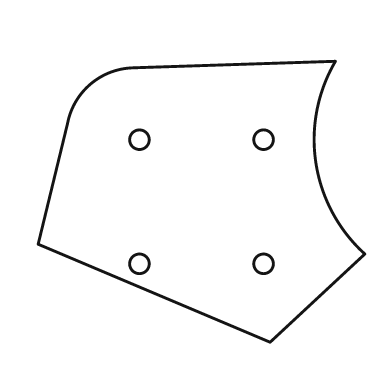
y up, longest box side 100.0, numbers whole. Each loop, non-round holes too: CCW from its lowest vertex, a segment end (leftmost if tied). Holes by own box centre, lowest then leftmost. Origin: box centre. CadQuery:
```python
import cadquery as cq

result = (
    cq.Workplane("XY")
    .moveTo(21.0, -43.0)
    .lineTo(50.0, -16.0)
    .threePointArc((35.0, 12.0), (41.0, 43.0))
    .lineTo(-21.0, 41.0)
    .threePointArc((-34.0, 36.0), (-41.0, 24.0))
    .lineTo(-50.0, -13.0)
    .close()
    .moveTo(-19.0, -19.0)
    .circle(3.0)
    .moveTo(19.0, -19.0)
    .circle(3.0)
    .moveTo(-19.0, 19.0)
    .circle(3.0)
    .moveTo(19.0, 19.0)
    .circle(3.0)
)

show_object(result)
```